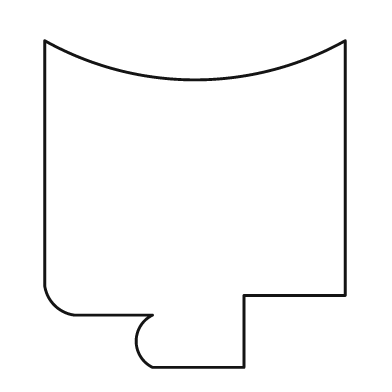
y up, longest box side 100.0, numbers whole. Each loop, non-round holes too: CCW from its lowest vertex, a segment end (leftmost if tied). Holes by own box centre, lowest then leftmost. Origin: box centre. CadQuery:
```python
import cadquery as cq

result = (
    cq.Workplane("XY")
    .moveTo(-13.0, -50.0)
    .lineTo(15.0, -50.0)
    .lineTo(15.0, -28.0)
    .lineTo(46.0, -28.0)
    .lineTo(46.0, 50.0)
    .threePointArc((0.0, 38.0), (-46.0, 50.0))
    .lineTo(-46.0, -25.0)
    .threePointArc((-43.0, -31.0), (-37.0, -34.0))
    .lineTo(-13.0, -34.0)
    .threePointArc((-18.0, -42.0), (-13.0, -50.0))
    .close()
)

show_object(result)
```